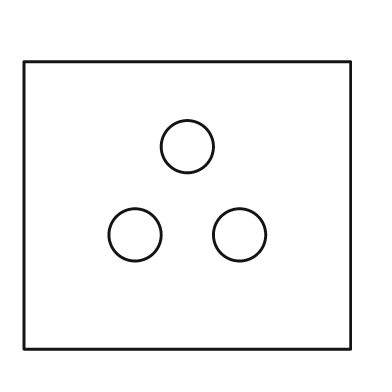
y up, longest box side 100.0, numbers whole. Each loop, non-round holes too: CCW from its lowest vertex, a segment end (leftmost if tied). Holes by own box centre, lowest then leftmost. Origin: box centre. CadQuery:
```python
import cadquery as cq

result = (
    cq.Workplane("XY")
    .moveTo(-50.0, -44.0)
    .lineTo(50.0, -44.0)
    .lineTo(50.0, 44.0)
    .lineTo(-50.0, 44.0)
    .close()
    .moveTo(-16.0, -9.0)
    .circle(8.0)
    .moveTo(16.0, -9.0)
    .circle(8.0)
    .moveTo(0.0, 18.0)
    .circle(8.0)
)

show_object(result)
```